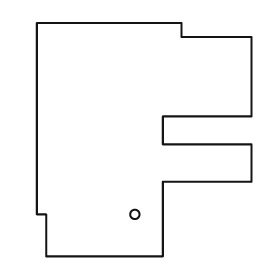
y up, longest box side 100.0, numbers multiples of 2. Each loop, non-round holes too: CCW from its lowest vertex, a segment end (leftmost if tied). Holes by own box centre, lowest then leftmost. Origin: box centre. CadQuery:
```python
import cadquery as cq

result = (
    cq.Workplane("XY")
    .moveTo(-42.0, -50.0)
    .lineTo(8.0, -50.0)
    .lineTo(8.0, -18.0)
    .lineTo(46.0, -18.0)
    .lineTo(46.0, -2.0)
    .lineTo(8.0, -2.0)
    .lineTo(8.0, 10.0)
    .lineTo(46.0, 10.0)
    .lineTo(46.0, 44.0)
    .lineTo(16.0, 44.0)
    .lineTo(16.0, 50.0)
    .lineTo(-46.0, 50.0)
    .lineTo(-46.0, -32.0)
    .lineTo(-42.0, -32.0)
    .close()
    .moveTo(-4.0, -32.0)
    .circle(2.0)
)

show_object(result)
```